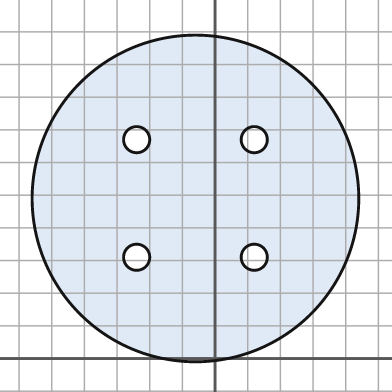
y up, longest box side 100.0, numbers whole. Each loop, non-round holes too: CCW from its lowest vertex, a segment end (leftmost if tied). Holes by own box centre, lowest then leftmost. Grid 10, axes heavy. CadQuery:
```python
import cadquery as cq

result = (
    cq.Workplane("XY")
    .moveTo(-6.0, 49.0)
    .circle(50.0)
    .moveTo(-24.0, 31.0)
    .circle(4.0)
    .moveTo(12.0, 31.0)
    .circle(4.0)
    .moveTo(-24.0, 67.0)
    .circle(4.0)
    .moveTo(12.0, 67.0)
    .circle(4.0)
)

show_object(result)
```